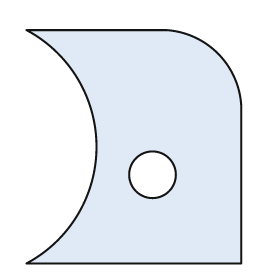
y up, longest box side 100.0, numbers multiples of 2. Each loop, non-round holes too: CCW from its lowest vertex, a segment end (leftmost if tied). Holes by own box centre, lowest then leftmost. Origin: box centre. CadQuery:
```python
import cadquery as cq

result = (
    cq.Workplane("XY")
    .moveTo(-46.0, -50.0)
    .lineTo(46.0, -50.0)
    .lineTo(46.0, 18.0)
    .threePointArc((36.0, 40.0), (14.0, 50.0))
    .lineTo(-46.0, 50.0)
    .threePointArc((-16.0, 0.0), (-46.0, -50.0))
    .close()
    .moveTo(8.0, -12.0)
    .circle(10.0)
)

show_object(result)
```